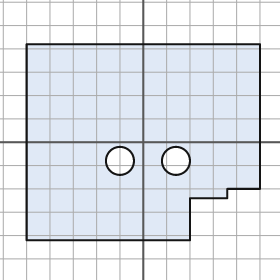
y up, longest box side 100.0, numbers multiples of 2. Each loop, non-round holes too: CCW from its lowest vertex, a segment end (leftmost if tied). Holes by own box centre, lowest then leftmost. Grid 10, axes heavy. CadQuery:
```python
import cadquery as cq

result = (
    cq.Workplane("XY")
    .moveTo(-50.0, -42.0)
    .lineTo(20.0, -42.0)
    .lineTo(20.0, -24.0)
    .lineTo(36.0, -24.0)
    .lineTo(36.0, -20.0)
    .lineTo(50.0, -20.0)
    .lineTo(50.0, 42.0)
    .lineTo(-50.0, 42.0)
    .close()
    .moveTo(-10.0, -8.0)
    .circle(6.0)
    .moveTo(14.0, -8.0)
    .circle(6.0)
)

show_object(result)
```